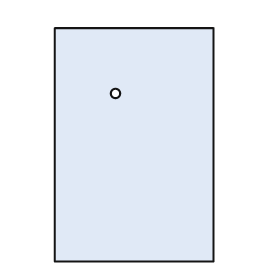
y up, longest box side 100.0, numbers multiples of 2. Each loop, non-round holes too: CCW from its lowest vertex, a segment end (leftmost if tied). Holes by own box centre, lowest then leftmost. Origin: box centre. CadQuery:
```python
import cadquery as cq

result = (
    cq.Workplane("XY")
    .moveTo(-34.0, -50.0)
    .lineTo(34.0, -50.0)
    .lineTo(34.0, 50.0)
    .lineTo(-34.0, 50.0)
    .close()
    .moveTo(-8.0, 22.0)
    .circle(2.0)
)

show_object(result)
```